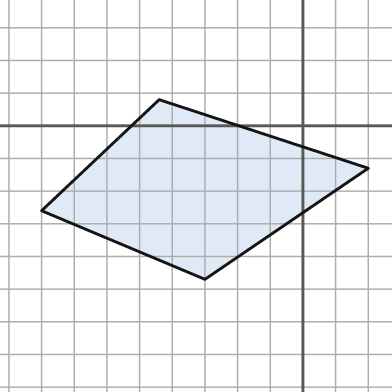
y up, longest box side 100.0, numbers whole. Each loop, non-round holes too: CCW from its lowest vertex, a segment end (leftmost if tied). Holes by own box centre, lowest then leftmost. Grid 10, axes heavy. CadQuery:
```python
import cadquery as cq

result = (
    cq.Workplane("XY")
    .moveTo(-30.0, -47.0)
    .lineTo(20.0, -13.0)
    .lineTo(-44.0, 8.0)
    .lineTo(-80.0, -26.0)
    .close()
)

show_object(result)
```